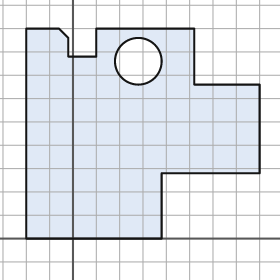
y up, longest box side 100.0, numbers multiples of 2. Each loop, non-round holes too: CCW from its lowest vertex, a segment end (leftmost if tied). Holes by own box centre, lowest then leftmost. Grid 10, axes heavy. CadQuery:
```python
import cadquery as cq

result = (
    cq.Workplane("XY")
    .moveTo(-20.0, 0.0)
    .lineTo(38.0, 0.0)
    .lineTo(38.0, 28.0)
    .lineTo(80.0, 28.0)
    .lineTo(80.0, 66.0)
    .lineTo(52.0, 66.0)
    .lineTo(52.0, 90.0)
    .lineTo(10.0, 90.0)
    .lineTo(10.0, 78.0)
    .lineTo(-2.0, 78.0)
    .lineTo(-2.0, 86.0)
    .lineTo(-6.0, 90.0)
    .lineTo(-20.0, 90.0)
    .close()
    .moveTo(28.0, 76.0)
    .circle(10.0)
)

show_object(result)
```